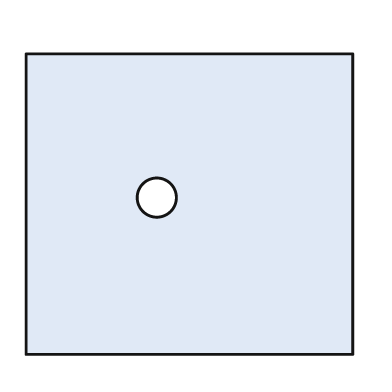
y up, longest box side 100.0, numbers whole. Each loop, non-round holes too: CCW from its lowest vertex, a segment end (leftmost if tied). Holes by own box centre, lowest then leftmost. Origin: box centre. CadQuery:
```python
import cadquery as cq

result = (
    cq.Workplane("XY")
    .moveTo(-50.0, -46.0)
    .lineTo(50.0, -46.0)
    .lineTo(50.0, 46.0)
    .lineTo(-50.0, 46.0)
    .close()
    .moveTo(-10.0, 2.0)
    .circle(6.0)
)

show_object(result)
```